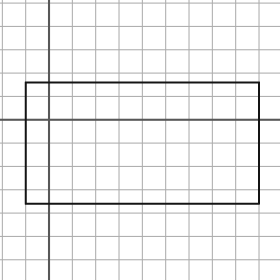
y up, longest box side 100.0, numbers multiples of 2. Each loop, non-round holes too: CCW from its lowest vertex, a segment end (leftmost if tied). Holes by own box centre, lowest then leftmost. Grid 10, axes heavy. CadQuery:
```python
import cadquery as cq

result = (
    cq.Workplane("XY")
    .moveTo(-10.0, -36.0)
    .lineTo(90.0, -36.0)
    .lineTo(90.0, 16.0)
    .lineTo(-10.0, 16.0)
    .close()
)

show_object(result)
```